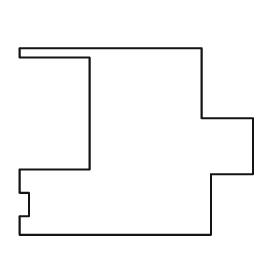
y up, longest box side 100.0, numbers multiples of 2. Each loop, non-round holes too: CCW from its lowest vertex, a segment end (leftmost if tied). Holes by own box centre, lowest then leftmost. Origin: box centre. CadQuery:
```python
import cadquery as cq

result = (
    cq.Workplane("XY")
    .moveTo(-50.0, -40.0)
    .lineTo(32.0, -40.0)
    .lineTo(32.0, -14.0)
    .lineTo(50.0, -14.0)
    .lineTo(50.0, 10.0)
    .lineTo(28.0, 10.0)
    .lineTo(28.0, 40.0)
    .lineTo(-50.0, 40.0)
    .lineTo(-50.0, 36.0)
    .lineTo(-20.0, 36.0)
    .lineTo(-20.0, -12.0)
    .lineTo(-50.0, -12.0)
    .lineTo(-50.0, -22.0)
    .lineTo(-46.0, -22.0)
    .lineTo(-46.0, -32.0)
    .lineTo(-50.0, -32.0)
    .close()
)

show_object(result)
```